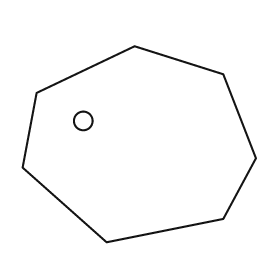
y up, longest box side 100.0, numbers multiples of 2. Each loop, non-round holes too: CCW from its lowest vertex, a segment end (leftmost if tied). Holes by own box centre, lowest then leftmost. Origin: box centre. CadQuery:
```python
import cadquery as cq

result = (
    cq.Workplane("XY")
    .moveTo(-14.0, -42.0)
    .lineTo(36.0, -32.0)
    .lineTo(50.0, -6.0)
    .lineTo(36.0, 30.0)
    .lineTo(-2.0, 42.0)
    .lineTo(-44.0, 22.0)
    .lineTo(-50.0, -10.0)
    .close()
    .moveTo(-24.0, 10.0)
    .circle(4.0)
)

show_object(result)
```